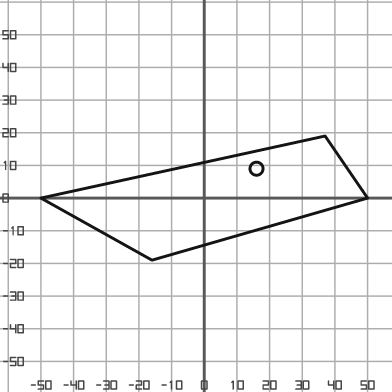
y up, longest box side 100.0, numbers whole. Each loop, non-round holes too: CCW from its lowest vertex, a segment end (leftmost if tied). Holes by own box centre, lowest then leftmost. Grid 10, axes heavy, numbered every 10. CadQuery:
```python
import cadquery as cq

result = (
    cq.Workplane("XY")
    .moveTo(-16.0, -19.0)
    .lineTo(50.0, 0.0)
    .lineTo(37.0, 19.0)
    .lineTo(-50.0, 0.0)
    .close()
    .moveTo(16.0, 9.0)
    .circle(2.0)
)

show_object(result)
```